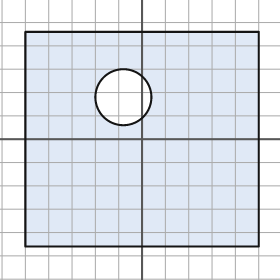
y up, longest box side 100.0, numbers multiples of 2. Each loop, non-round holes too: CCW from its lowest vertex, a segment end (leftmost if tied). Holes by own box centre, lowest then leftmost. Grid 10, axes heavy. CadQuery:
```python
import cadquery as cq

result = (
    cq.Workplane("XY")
    .moveTo(-50.0, -46.0)
    .lineTo(50.0, -46.0)
    .lineTo(50.0, 46.0)
    .lineTo(-50.0, 46.0)
    .close()
    .moveTo(-8.0, 18.0)
    .circle(12.0)
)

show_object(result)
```